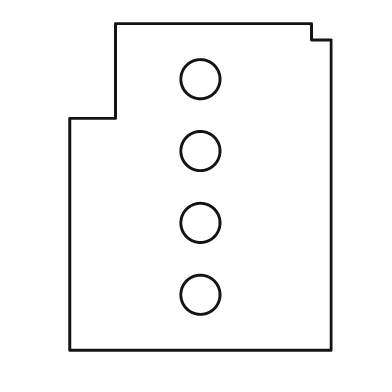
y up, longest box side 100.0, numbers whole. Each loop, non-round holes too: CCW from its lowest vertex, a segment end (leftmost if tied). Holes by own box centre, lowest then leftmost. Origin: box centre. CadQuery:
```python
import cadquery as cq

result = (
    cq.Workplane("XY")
    .moveTo(-40.0, -50.0)
    .lineTo(40.0, -50.0)
    .lineTo(40.0, 45.0)
    .lineTo(34.0, 45.0)
    .lineTo(34.0, 50.0)
    .lineTo(-26.0, 50.0)
    .lineTo(-26.0, 21.0)
    .lineTo(-40.0, 21.0)
    .close()
    .moveTo(0.0, -33.0)
    .circle(6.0)
    .moveTo(0.0, -11.0)
    .circle(6.0)
    .moveTo(0.0, 11.0)
    .circle(6.0)
    .moveTo(0.0, 33.0)
    .circle(6.0)
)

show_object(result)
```